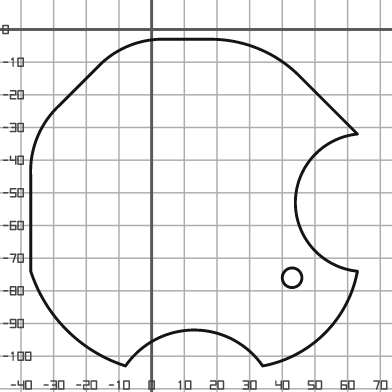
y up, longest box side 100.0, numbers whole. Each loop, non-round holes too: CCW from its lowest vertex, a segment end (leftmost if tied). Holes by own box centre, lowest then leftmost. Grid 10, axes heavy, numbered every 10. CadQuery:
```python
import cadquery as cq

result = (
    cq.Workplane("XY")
    .moveTo(-8.0, -103.0)
    .threePointArc((13.0, -92.0), (34.0, -103.0))
    .threePointArc((53.0, -93.0), (63.0, -74.0))
    .threePointArc((44.0, -53.0), (63.0, -32.0))
    .lineTo(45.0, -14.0)
    .threePointArc((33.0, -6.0), (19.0, -3.0))
    .lineTo(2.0, -3.0)
    .threePointArc((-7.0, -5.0), (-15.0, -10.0))
    .lineTo(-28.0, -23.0)
    .threePointArc((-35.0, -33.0), (-37.0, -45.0))
    .lineTo(-37.0, -74.0)
    .threePointArc((-26.0, -92.0), (-8.0, -103.0))
    .close()
    .moveTo(43.0, -76.0)
    .circle(3.0)
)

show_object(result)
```